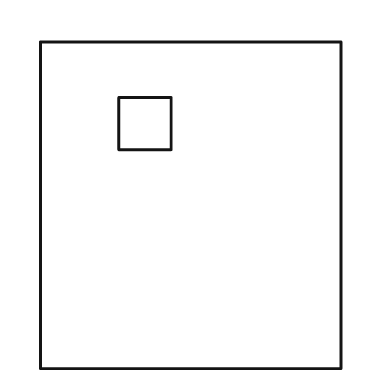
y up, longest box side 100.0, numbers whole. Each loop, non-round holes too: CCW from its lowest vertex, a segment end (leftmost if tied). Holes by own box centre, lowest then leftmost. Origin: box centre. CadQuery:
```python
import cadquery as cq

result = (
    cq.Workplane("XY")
    .moveTo(-46.0, -50.0)
    .lineTo(46.0, -50.0)
    .lineTo(46.0, 50.0)
    .lineTo(-46.0, 50.0)
    .close()
    .moveTo(-22.0, 17.0)
    .lineTo(-6.0, 17.0)
    .lineTo(-6.0, 33.0)
    .lineTo(-22.0, 33.0)
    .close()
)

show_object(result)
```